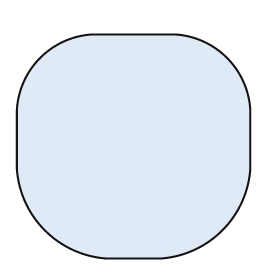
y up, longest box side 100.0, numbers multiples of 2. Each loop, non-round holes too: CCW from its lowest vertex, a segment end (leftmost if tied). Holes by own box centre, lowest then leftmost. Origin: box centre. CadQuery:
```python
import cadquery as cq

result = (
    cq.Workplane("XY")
    .moveTo(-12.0, -48.0)
    .lineTo(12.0, -48.0)
    .threePointArc((38.0, -36.0), (50.0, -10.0))
    .lineTo(50.0, 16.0)
    .threePointArc((40.0, 38.0), (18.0, 48.0))
    .lineTo(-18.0, 48.0)
    .threePointArc((-40.0, 38.0), (-50.0, 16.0))
    .lineTo(-50.0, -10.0)
    .threePointArc((-38.0, -36.0), (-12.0, -48.0))
    .close()
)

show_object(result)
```